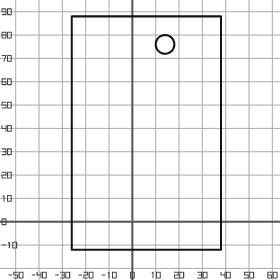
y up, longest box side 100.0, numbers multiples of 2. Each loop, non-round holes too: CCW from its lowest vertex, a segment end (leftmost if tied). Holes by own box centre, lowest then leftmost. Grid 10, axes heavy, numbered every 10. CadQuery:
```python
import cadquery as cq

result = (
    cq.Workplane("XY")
    .moveTo(-26.0, -12.0)
    .lineTo(38.0, -12.0)
    .lineTo(38.0, 88.0)
    .lineTo(-26.0, 88.0)
    .close()
    .moveTo(14.0, 76.0)
    .circle(4.0)
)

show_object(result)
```